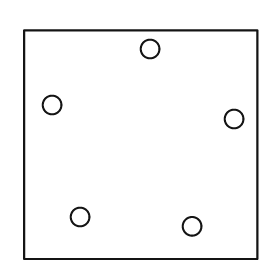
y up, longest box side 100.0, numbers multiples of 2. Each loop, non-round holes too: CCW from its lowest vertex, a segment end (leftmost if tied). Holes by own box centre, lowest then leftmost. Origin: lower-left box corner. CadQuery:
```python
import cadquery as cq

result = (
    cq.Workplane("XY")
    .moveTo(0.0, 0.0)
    .lineTo(100.0, 0.0)
    .lineTo(100.0, 98.0)
    .lineTo(0.0, 98.0)
    .close()
    .moveTo(72.0, 14.0)
    .circle(4.0)
    .moveTo(24.0, 18.0)
    .circle(4.0)
    .moveTo(90.0, 60.0)
    .circle(4.0)
    .moveTo(12.0, 66.0)
    .circle(4.0)
    .moveTo(54.0, 90.0)
    .circle(4.0)
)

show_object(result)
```